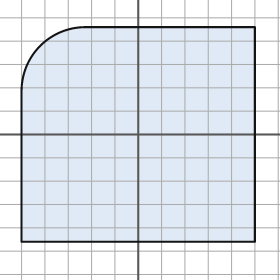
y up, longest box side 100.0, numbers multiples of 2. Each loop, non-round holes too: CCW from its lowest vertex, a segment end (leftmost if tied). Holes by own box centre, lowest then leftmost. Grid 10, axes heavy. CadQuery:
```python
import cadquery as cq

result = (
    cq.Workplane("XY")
    .moveTo(-50.0, -46.0)
    .lineTo(50.0, -46.0)
    .lineTo(50.0, 46.0)
    .lineTo(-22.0, 46.0)
    .threePointArc((-42.0, 38.0), (-50.0, 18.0))
    .close()
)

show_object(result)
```